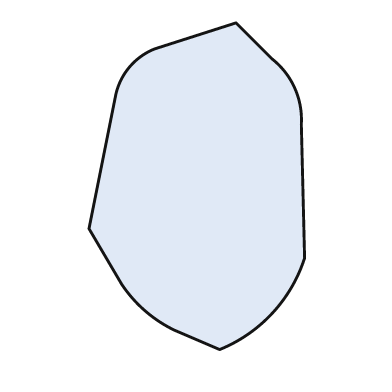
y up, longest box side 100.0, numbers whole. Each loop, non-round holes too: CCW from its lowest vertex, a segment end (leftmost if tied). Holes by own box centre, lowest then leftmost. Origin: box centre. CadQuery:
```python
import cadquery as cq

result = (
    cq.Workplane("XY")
    .moveTo(7.0, -50.0)
    .threePointArc((23.0, -39.0), (33.0, -22.0))
    .lineTo(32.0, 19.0)
    .threePointArc((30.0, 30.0), (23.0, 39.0))
    .lineTo(12.0, 50.0)
    .lineTo(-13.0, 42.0)
    .threePointArc((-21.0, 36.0), (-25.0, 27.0))
    .lineTo(-33.0, -13.0)
    .lineTo(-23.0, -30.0)
    .threePointArc((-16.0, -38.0), (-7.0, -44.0))
    .close()
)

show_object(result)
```